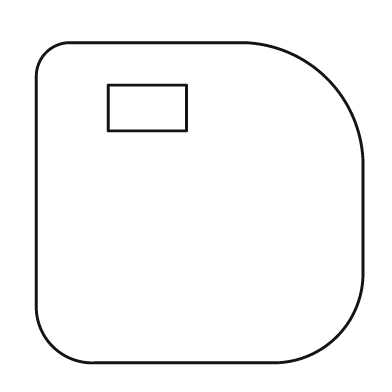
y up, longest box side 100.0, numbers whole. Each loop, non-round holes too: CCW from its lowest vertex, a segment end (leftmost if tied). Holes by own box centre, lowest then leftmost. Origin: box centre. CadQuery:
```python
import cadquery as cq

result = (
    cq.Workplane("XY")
    .moveTo(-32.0, -49.0)
    .lineTo(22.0, -49.0)
    .threePointArc((42.0, -41.0), (50.0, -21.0))
    .lineTo(50.0, 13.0)
    .threePointArc((39.0, 38.0), (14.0, 49.0))
    .lineTo(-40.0, 49.0)
    .threePointArc((-47.0, 46.0), (-50.0, 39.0))
    .lineTo(-50.0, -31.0)
    .threePointArc((-45.0, -44.0), (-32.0, -49.0))
    .close()
    .moveTo(-28.0, 22.0)
    .lineTo(-4.0, 22.0)
    .lineTo(-4.0, 36.0)
    .lineTo(-28.0, 36.0)
    .close()
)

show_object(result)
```